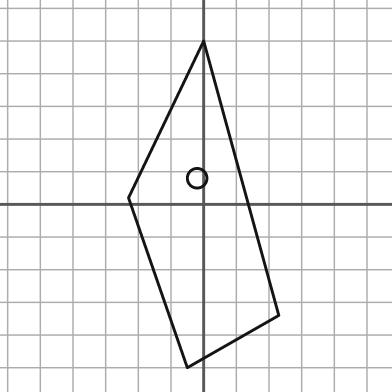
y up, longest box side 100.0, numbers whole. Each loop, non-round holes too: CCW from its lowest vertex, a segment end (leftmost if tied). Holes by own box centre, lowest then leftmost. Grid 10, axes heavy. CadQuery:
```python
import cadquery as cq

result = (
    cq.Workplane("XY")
    .moveTo(-5.0, -50.0)
    .lineTo(23.0, -34.0)
    .lineTo(0.0, 50.0)
    .lineTo(-23.0, 2.0)
    .close()
    .moveTo(-2.0, 8.0)
    .circle(3.0)
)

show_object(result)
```